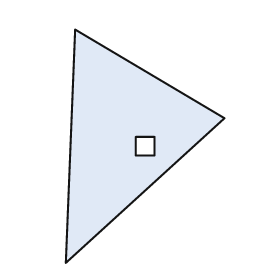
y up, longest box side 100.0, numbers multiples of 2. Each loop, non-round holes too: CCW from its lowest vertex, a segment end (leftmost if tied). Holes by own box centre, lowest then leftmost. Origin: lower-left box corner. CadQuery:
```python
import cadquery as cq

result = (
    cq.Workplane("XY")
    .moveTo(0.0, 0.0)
    .lineTo(68.0, 62.0)
    .lineTo(4.0, 100.0)
    .close()
    .moveTo(30.0, 46.0)
    .lineTo(38.0, 46.0)
    .lineTo(38.0, 54.0)
    .lineTo(30.0, 54.0)
    .close()
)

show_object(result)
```